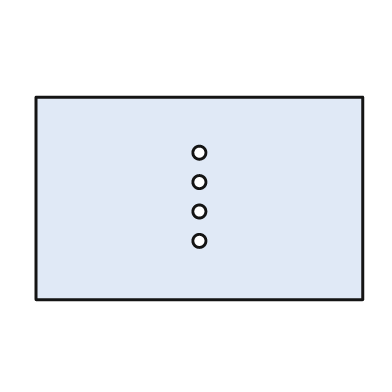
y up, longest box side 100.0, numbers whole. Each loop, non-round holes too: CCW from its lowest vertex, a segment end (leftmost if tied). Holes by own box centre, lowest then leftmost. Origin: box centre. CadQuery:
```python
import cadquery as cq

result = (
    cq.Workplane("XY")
    .moveTo(-50.0, -31.0)
    .lineTo(50.0, -31.0)
    .lineTo(50.0, 31.0)
    .lineTo(-50.0, 31.0)
    .close()
    .moveTo(0.0, -13.0)
    .circle(2.0)
    .moveTo(0.0, -4.0)
    .circle(2.0)
    .moveTo(0.0, 5.0)
    .circle(2.0)
    .moveTo(0.0, 14.0)
    .circle(2.0)
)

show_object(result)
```